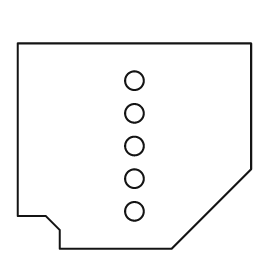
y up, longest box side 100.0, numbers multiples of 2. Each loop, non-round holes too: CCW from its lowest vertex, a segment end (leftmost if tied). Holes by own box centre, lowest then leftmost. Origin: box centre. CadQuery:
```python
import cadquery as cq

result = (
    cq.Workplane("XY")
    .moveTo(-32.0, -44.0)
    .lineTo(16.0, -44.0)
    .lineTo(50.0, -10.0)
    .lineTo(50.0, 44.0)
    .lineTo(-50.0, 44.0)
    .lineTo(-50.0, -30.0)
    .lineTo(-38.0, -30.0)
    .lineTo(-32.0, -36.0)
    .close()
    .moveTo(0.0, -28.0)
    .circle(4.0)
    .moveTo(0.0, -14.0)
    .circle(4.0)
    .moveTo(0.0, 0.0)
    .circle(4.0)
    .moveTo(0.0, 14.0)
    .circle(4.0)
    .moveTo(0.0, 28.0)
    .circle(4.0)
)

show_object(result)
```